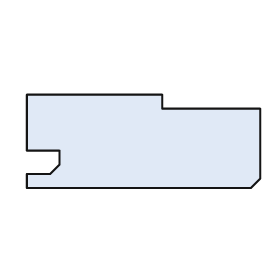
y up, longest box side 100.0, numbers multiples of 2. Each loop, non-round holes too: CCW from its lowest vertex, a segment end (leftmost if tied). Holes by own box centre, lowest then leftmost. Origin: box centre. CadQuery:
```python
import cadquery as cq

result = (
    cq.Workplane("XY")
    .moveTo(-50.0, -20.0)
    .lineTo(46.0, -20.0)
    .lineTo(50.0, -16.0)
    .lineTo(50.0, 14.0)
    .lineTo(8.0, 14.0)
    .lineTo(8.0, 20.0)
    .lineTo(-50.0, 20.0)
    .lineTo(-50.0, -4.0)
    .lineTo(-36.0, -4.0)
    .lineTo(-36.0, -10.0)
    .lineTo(-40.0, -14.0)
    .lineTo(-50.0, -14.0)
    .close()
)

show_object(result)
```